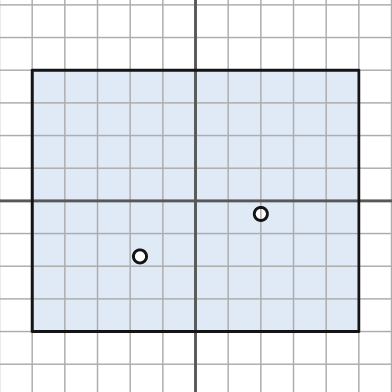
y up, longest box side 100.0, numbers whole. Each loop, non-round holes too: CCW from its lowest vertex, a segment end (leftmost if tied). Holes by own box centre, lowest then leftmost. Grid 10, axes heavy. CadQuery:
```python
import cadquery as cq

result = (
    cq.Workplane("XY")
    .moveTo(-50.0, -40.0)
    .lineTo(50.0, -40.0)
    .lineTo(50.0, 40.0)
    .lineTo(-50.0, 40.0)
    .close()
    .moveTo(-17.0, -17.0)
    .circle(2.0)
    .moveTo(20.0, -4.0)
    .circle(2.0)
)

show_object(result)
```